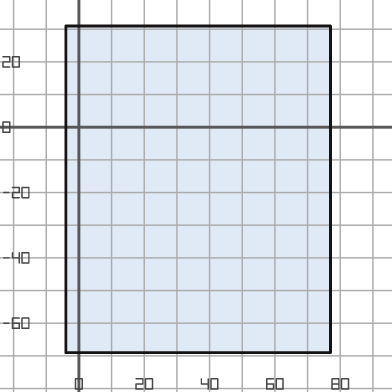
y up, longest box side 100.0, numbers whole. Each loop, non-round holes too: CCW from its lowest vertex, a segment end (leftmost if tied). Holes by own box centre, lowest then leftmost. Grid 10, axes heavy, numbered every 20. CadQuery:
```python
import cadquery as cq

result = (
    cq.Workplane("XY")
    .moveTo(-4.0, -69.0)
    .lineTo(77.0, -69.0)
    .lineTo(77.0, 31.0)
    .lineTo(-4.0, 31.0)
    .close()
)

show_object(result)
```